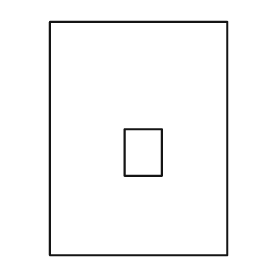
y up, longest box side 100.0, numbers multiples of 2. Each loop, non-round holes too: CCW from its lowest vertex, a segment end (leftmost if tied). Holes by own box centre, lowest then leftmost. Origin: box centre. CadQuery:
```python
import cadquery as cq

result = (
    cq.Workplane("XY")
    .moveTo(-38.0, -50.0)
    .lineTo(38.0, -50.0)
    .lineTo(38.0, 50.0)
    .lineTo(-38.0, 50.0)
    .close()
    .moveTo(-6.0, -16.0)
    .lineTo(10.0, -16.0)
    .lineTo(10.0, 4.0)
    .lineTo(-6.0, 4.0)
    .close()
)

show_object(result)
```